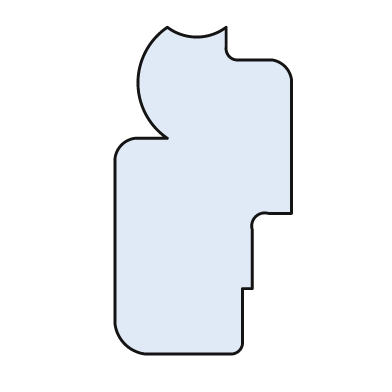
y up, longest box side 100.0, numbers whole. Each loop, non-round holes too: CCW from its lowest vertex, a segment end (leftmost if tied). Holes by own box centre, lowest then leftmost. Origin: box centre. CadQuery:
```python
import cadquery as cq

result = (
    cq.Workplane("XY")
    .moveTo(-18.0, -50.0)
    .lineTo(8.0, -50.0)
    .threePointArc((11.0, -49.0), (12.0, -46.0))
    .lineTo(12.0, -30.0)
    .lineTo(15.0, -30.0)
    .lineTo(15.0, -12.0)
    .threePointArc((16.0, -8.0), (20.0, -7.0))
    .lineTo(27.0, -7.0)
    .lineTo(27.0, 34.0)
    .threePointArc((25.0, 38.0), (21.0, 40.0))
    .lineTo(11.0, 40.0)
    .threePointArc((8.0, 41.0), (7.0, 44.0))
    .lineTo(7.0, 50.0)
    .threePointArc((-2.0, 47.0), (-11.0, 50.0))
    .threePointArc((-20.0, 33.0), (-11.0, 16.0))
    .lineTo(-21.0, 16.0)
    .threePointArc((-25.0, 14.0), (-27.0, 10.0))
    .lineTo(-27.0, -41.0)
    .threePointArc((-24.0, -47.0), (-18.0, -50.0))
    .close()
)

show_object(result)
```